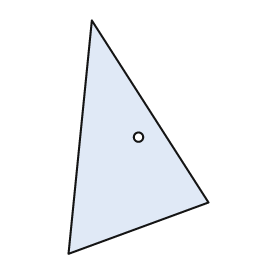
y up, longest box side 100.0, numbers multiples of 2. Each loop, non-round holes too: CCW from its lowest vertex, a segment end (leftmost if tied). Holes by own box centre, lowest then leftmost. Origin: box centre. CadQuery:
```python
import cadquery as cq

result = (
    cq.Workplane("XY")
    .moveTo(-30.0, -50.0)
    .lineTo(30.0, -28.0)
    .lineTo(-20.0, 50.0)
    .close()
    .moveTo(0.0, 0.0)
    .circle(2.0)
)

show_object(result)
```